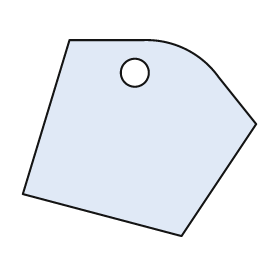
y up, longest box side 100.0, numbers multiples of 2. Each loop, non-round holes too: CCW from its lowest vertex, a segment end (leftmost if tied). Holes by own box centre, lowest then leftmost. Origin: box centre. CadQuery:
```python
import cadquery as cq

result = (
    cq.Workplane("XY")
    .moveTo(18.0, -42.0)
    .lineTo(50.0, 6.0)
    .lineTo(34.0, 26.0)
    .threePointArc((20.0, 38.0), (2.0, 42.0))
    .lineTo(-30.0, 42.0)
    .lineTo(-50.0, -24.0)
    .close()
    .moveTo(-2.0, 28.0)
    .circle(6.0)
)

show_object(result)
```